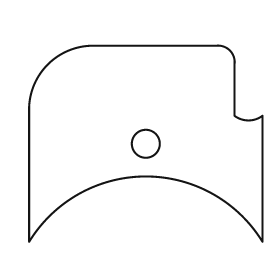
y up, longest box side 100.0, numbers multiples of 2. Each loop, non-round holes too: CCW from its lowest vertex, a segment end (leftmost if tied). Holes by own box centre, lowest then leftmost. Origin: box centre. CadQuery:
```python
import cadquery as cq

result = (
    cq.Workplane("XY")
    .moveTo(-50.0, -42.0)
    .threePointArc((0.0, -14.0), (50.0, -42.0))
    .lineTo(50.0, 12.0)
    .threePointArc((44.0, 10.0), (38.0, 12.0))
    .lineTo(38.0, 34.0)
    .threePointArc((36.0, 40.0), (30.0, 42.0))
    .lineTo(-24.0, 42.0)
    .threePointArc((-42.0, 34.0), (-50.0, 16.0))
    .close()
    .moveTo(0.0, 0.0)
    .circle(6.0)
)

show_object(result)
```